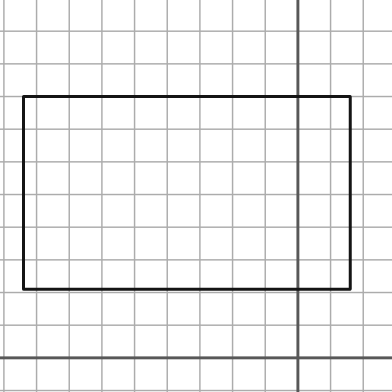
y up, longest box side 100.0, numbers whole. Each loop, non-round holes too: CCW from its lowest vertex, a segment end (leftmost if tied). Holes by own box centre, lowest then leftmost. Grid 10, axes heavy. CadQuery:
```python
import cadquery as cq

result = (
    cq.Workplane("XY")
    .moveTo(-84.0, 21.0)
    .lineTo(16.0, 21.0)
    .lineTo(16.0, 80.0)
    .lineTo(-84.0, 80.0)
    .close()
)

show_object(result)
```